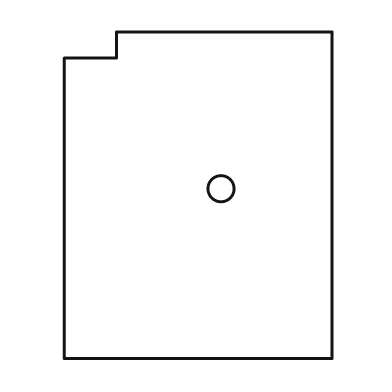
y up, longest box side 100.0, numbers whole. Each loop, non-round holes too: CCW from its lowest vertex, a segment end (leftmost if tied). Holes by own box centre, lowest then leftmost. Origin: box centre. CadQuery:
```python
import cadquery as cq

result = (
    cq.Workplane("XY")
    .moveTo(-41.0, -50.0)
    .lineTo(41.0, -50.0)
    .lineTo(41.0, 50.0)
    .lineTo(-25.0, 50.0)
    .lineTo(-25.0, 42.0)
    .lineTo(-41.0, 42.0)
    .close()
    .moveTo(7.0, 2.0)
    .circle(4.0)
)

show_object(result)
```